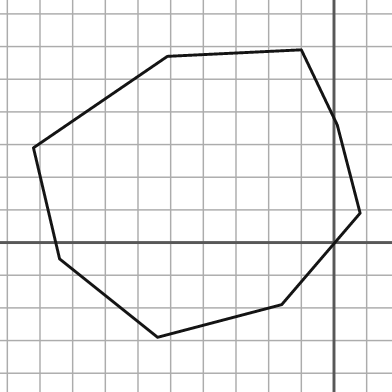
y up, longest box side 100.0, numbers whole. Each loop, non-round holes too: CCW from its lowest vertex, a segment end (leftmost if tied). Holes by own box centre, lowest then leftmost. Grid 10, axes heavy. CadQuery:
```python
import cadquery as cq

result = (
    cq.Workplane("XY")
    .moveTo(-54.0, -29.0)
    .lineTo(-16.0, -19.0)
    .lineTo(8.0, 9.0)
    .lineTo(1.0, 36.0)
    .lineTo(-10.0, 59.0)
    .lineTo(-51.0, 57.0)
    .lineTo(-92.0, 29.0)
    .lineTo(-84.0, -5.0)
    .close()
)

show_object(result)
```